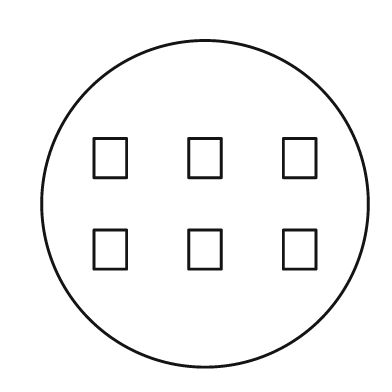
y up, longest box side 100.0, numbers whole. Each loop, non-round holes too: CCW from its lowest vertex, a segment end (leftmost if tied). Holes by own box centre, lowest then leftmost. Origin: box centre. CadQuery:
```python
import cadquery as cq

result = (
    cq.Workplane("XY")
    .moveTo(0.0, 0.0)
    .circle(50.0)
    .moveTo(-34.0, -20.0)
    .lineTo(-24.0, -20.0)
    .lineTo(-24.0, -8.0)
    .lineTo(-34.0, -8.0)
    .close()
    .moveTo(-5.0, -20.0)
    .lineTo(5.0, -20.0)
    .lineTo(5.0, -8.0)
    .lineTo(-5.0, -8.0)
    .close()
    .moveTo(24.0, -20.0)
    .lineTo(34.0, -20.0)
    .lineTo(34.0, -8.0)
    .lineTo(24.0, -8.0)
    .close()
    .moveTo(-34.0, 8.0)
    .lineTo(-24.0, 8.0)
    .lineTo(-24.0, 20.0)
    .lineTo(-34.0, 20.0)
    .close()
    .moveTo(-5.0, 8.0)
    .lineTo(5.0, 8.0)
    .lineTo(5.0, 20.0)
    .lineTo(-5.0, 20.0)
    .close()
    .moveTo(24.0, 8.0)
    .lineTo(34.0, 8.0)
    .lineTo(34.0, 20.0)
    .lineTo(24.0, 20.0)
    .close()
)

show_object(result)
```